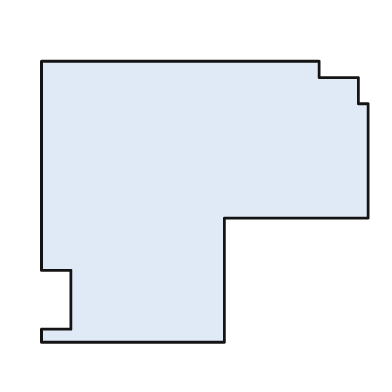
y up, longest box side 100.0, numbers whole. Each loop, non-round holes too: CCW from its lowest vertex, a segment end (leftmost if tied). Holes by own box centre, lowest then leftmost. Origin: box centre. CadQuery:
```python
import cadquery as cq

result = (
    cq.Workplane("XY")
    .moveTo(-50.0, -43.0)
    .lineTo(6.0, -43.0)
    .lineTo(6.0, -5.0)
    .lineTo(50.0, -5.0)
    .lineTo(50.0, 30.0)
    .lineTo(47.0, 30.0)
    .lineTo(47.0, 38.0)
    .lineTo(35.0, 38.0)
    .lineTo(35.0, 43.0)
    .lineTo(-50.0, 43.0)
    .lineTo(-50.0, -21.0)
    .lineTo(-41.0, -21.0)
    .lineTo(-41.0, -39.0)
    .lineTo(-50.0, -39.0)
    .close()
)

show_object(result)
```